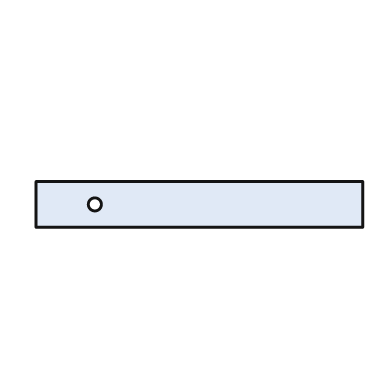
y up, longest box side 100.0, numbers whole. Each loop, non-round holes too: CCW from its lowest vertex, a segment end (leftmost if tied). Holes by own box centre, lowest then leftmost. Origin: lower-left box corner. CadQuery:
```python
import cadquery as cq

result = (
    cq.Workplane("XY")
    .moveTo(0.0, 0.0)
    .lineTo(100.0, 0.0)
    .lineTo(100.0, 14.0)
    .lineTo(0.0, 14.0)
    .close()
    .moveTo(18.0, 7.0)
    .circle(2.0)
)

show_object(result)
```